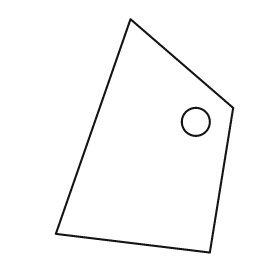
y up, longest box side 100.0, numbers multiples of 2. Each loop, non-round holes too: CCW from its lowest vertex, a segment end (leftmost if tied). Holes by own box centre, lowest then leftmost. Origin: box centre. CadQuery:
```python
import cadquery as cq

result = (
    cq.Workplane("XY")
    .moveTo(28.0, -50.0)
    .lineTo(38.0, 12.0)
    .lineTo(-6.0, 50.0)
    .lineTo(-38.0, -42.0)
    .close()
    .moveTo(22.0, 6.0)
    .circle(6.0)
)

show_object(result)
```